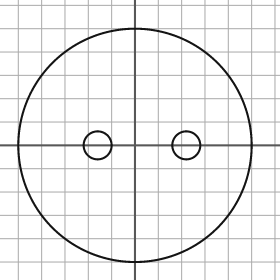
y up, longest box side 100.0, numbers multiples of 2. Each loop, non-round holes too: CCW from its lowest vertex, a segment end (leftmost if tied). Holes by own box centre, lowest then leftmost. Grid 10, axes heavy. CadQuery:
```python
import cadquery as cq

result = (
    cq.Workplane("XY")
    .moveTo(0.0, 0.0)
    .circle(50.0)
    .moveTo(-16.0, 0.0)
    .circle(6.0)
    .moveTo(22.0, 0.0)
    .circle(6.0)
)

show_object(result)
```